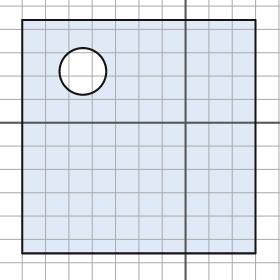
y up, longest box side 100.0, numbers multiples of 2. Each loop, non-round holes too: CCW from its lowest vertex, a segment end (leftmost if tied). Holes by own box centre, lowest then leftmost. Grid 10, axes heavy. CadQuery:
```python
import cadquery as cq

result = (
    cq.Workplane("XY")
    .moveTo(-70.0, -56.0)
    .lineTo(30.0, -56.0)
    .lineTo(30.0, 44.0)
    .lineTo(-70.0, 44.0)
    .close()
    .moveTo(-44.0, 22.0)
    .circle(10.0)
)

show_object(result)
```